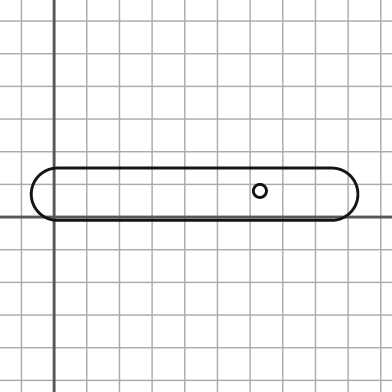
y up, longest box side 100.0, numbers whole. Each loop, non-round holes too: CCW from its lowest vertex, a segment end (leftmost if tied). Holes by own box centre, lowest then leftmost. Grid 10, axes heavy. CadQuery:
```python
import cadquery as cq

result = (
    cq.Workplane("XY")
    .moveTo(1.0, -1.0)
    .lineTo(85.0, -1.0)
    .threePointArc((93.0, 7.0), (85.0, 15.0))
    .lineTo(1.0, 15.0)
    .threePointArc((-7.0, 7.0), (1.0, -1.0))
    .close()
    .moveTo(63.0, 8.0)
    .circle(2.0)
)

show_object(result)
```